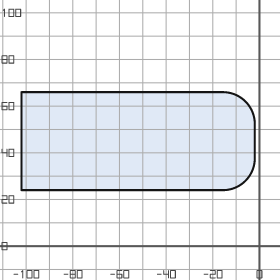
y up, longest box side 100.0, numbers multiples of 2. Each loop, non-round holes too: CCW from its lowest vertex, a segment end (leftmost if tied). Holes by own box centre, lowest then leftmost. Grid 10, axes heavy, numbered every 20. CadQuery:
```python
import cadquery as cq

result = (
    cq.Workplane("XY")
    .moveTo(-102.0, 24.0)
    .lineTo(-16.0, 24.0)
    .threePointArc((-6.0, 28.0), (-2.0, 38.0))
    .lineTo(-2.0, 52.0)
    .threePointArc((-6.0, 62.0), (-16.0, 66.0))
    .lineTo(-102.0, 66.0)
    .close()
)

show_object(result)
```